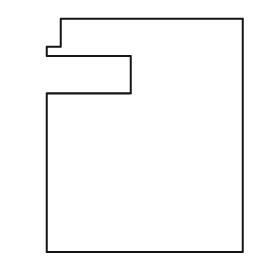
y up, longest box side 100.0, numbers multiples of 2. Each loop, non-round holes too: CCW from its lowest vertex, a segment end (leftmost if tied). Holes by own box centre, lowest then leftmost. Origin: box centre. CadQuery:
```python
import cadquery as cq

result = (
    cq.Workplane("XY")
    .moveTo(-42.0, -50.0)
    .lineTo(42.0, -50.0)
    .lineTo(42.0, 50.0)
    .lineTo(-36.0, 50.0)
    .lineTo(-36.0, 38.0)
    .lineTo(-42.0, 38.0)
    .lineTo(-42.0, 34.0)
    .lineTo(-6.0, 34.0)
    .lineTo(-6.0, 18.0)
    .lineTo(-42.0, 18.0)
    .close()
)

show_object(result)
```